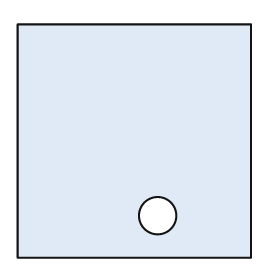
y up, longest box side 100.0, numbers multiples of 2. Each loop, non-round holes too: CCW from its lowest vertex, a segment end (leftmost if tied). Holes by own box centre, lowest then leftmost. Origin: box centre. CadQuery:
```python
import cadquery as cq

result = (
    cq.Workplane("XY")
    .moveTo(-50.0, -50.0)
    .lineTo(50.0, -50.0)
    .lineTo(50.0, 50.0)
    .lineTo(-50.0, 50.0)
    .close()
    .moveTo(10.0, -32.0)
    .circle(8.0)
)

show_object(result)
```